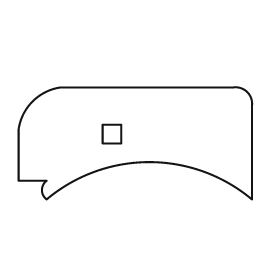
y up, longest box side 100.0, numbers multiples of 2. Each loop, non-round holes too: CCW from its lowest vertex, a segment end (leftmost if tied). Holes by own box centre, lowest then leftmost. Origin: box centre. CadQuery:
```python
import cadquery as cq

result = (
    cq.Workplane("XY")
    .moveTo(-38.0, -24.0)
    .threePointArc((6.0, -8.0), (50.0, -24.0))
    .lineTo(50.0, 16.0)
    .threePointArc((48.0, 22.0), (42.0, 24.0))
    .lineTo(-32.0, 24.0)
    .threePointArc((-44.0, 18.0), (-50.0, 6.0))
    .lineTo(-50.0, -16.0)
    .lineTo(-38.0, -16.0)
    .threePointArc((-40.0, -20.0), (-38.0, -24.0))
    .close()
    .moveTo(-14.0, 0.0)
    .lineTo(-6.0, 0.0)
    .lineTo(-6.0, 8.0)
    .lineTo(-14.0, 8.0)
    .close()
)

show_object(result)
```